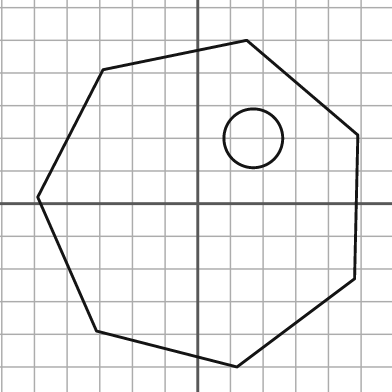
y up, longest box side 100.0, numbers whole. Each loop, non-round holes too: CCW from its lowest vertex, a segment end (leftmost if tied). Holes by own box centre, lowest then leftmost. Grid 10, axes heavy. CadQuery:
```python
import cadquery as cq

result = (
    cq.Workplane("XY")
    .moveTo(12.0, -50.0)
    .lineTo(48.0, -23.0)
    .lineTo(49.0, 21.0)
    .lineTo(15.0, 50.0)
    .lineTo(-29.0, 41.0)
    .lineTo(-49.0, 2.0)
    .lineTo(-31.0, -39.0)
    .close()
    .moveTo(17.0, 20.0)
    .circle(9.0)
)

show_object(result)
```